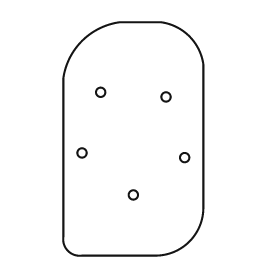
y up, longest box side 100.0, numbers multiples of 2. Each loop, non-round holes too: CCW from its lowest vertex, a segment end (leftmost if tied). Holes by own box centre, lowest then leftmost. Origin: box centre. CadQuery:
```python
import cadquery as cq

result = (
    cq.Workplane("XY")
    .moveTo(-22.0, -50.0)
    .lineTo(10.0, -50.0)
    .threePointArc((24.0, -44.0), (30.0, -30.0))
    .lineTo(30.0, 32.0)
    .threePointArc((24.0, 44.0), (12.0, 50.0))
    .lineTo(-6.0, 50.0)
    .threePointArc((-22.0, 42.0), (-30.0, 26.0))
    .lineTo(-30.0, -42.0)
    .threePointArc((-28.0, -48.0), (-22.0, -50.0))
    .close()
    .moveTo(0.0, -24.0)
    .circle(2.0)
    .moveTo(22.0, -8.0)
    .circle(2.0)
    .moveTo(-22.0, -6.0)
    .circle(2.0)
    .moveTo(14.0, 18.0)
    .circle(2.0)
    .moveTo(-14.0, 20.0)
    .circle(2.0)
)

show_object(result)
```